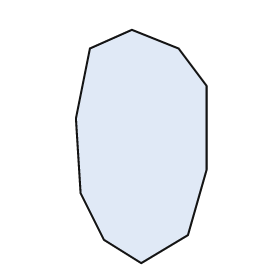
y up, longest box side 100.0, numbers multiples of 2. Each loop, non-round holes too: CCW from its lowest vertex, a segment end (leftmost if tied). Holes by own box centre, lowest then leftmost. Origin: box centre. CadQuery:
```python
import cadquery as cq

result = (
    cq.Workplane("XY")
    .moveTo(0.0, -50.0)
    .lineTo(20.0, -38.0)
    .lineTo(28.0, -10.0)
    .lineTo(28.0, 26.0)
    .lineTo(16.0, 42.0)
    .lineTo(-4.0, 50.0)
    .lineTo(-22.0, 42.0)
    .lineTo(-28.0, 12.0)
    .lineTo(-26.0, -20.0)
    .lineTo(-16.0, -40.0)
    .close()
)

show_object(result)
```